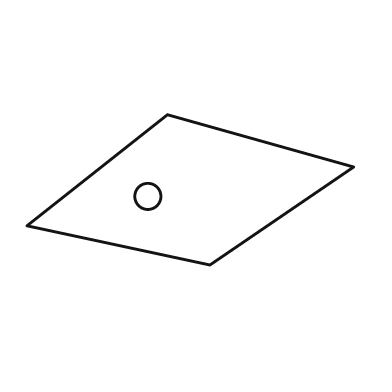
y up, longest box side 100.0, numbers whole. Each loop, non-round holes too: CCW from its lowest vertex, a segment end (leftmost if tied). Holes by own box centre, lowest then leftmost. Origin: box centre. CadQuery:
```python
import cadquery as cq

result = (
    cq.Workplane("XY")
    .moveTo(6.0, -23.0)
    .lineTo(50.0, 7.0)
    .lineTo(-7.0, 23.0)
    .lineTo(-50.0, -11.0)
    .close()
    .moveTo(-13.0, -2.0)
    .circle(4.0)
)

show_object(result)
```